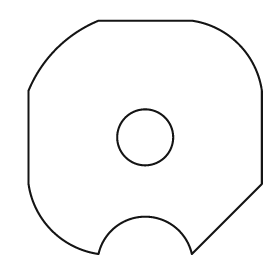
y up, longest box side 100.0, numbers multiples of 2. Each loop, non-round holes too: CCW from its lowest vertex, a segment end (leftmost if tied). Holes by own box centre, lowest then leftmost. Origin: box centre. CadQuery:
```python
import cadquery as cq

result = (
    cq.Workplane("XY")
    .moveTo(-20.0, -50.0)
    .threePointArc((0.0, -34.0), (20.0, -50.0))
    .lineTo(50.0, -20.0)
    .lineTo(50.0, 20.0)
    .threePointArc((40.0, 40.0), (20.0, 50.0))
    .lineTo(-20.0, 50.0)
    .threePointArc((-38.0, 38.0), (-50.0, 20.0))
    .lineTo(-50.0, -20.0)
    .threePointArc((-40.0, -40.0), (-20.0, -50.0))
    .close()
    .moveTo(0.0, 0.0)
    .circle(12.0)
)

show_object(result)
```